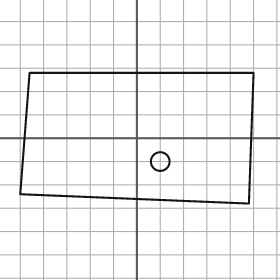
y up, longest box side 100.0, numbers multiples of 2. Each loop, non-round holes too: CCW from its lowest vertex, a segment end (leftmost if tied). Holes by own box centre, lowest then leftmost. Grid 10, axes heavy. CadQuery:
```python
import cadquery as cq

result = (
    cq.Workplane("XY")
    .moveTo(48.0, -28.0)
    .lineTo(50.0, 28.0)
    .lineTo(-46.0, 28.0)
    .lineTo(-50.0, -24.0)
    .close()
    .moveTo(10.0, -10.0)
    .circle(4.0)
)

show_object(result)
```